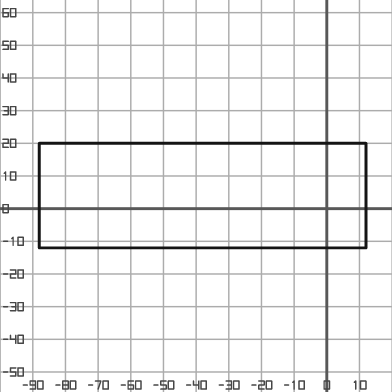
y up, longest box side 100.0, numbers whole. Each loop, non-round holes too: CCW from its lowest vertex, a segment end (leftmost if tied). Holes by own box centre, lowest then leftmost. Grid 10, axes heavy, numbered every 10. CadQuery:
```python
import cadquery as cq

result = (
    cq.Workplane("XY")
    .moveTo(-88.0, -12.0)
    .lineTo(12.0, -12.0)
    .lineTo(12.0, 20.0)
    .lineTo(-88.0, 20.0)
    .close()
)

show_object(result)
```